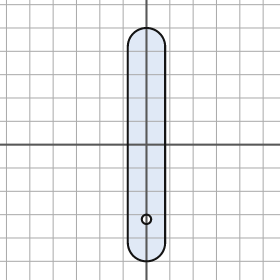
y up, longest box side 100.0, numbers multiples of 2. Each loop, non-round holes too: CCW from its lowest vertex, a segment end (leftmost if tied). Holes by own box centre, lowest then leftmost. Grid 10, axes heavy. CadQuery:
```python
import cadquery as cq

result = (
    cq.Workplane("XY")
    .moveTo(-8.0, -42.0)
    .threePointArc((0.0, -50.0), (8.0, -42.0))
    .lineTo(8.0, 42.0)
    .threePointArc((0.0, 50.0), (-8.0, 42.0))
    .close()
    .moveTo(0.0, -32.0)
    .circle(2.0)
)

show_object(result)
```